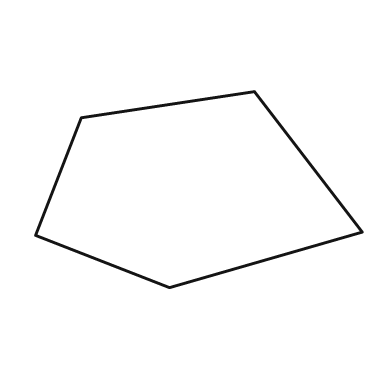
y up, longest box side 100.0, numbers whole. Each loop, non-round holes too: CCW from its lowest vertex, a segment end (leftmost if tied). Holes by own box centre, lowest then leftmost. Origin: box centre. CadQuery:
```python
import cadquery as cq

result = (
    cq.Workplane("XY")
    .moveTo(-9.0, -30.0)
    .lineTo(50.0, -13.0)
    .lineTo(17.0, 30.0)
    .lineTo(-36.0, 22.0)
    .lineTo(-50.0, -14.0)
    .close()
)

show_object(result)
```